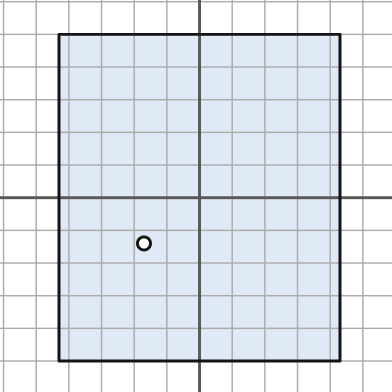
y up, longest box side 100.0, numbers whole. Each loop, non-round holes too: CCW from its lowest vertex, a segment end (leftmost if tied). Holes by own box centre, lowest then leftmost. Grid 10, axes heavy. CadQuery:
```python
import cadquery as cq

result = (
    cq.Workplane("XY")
    .moveTo(-43.0, -50.0)
    .lineTo(43.0, -50.0)
    .lineTo(43.0, 50.0)
    .lineTo(-43.0, 50.0)
    .close()
    .moveTo(-17.0, -14.0)
    .circle(2.0)
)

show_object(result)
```